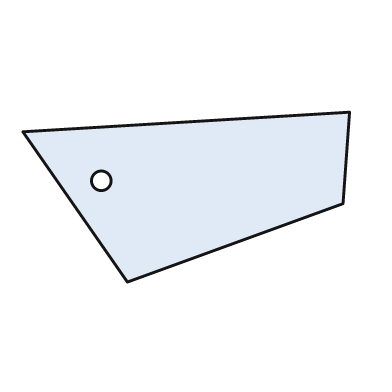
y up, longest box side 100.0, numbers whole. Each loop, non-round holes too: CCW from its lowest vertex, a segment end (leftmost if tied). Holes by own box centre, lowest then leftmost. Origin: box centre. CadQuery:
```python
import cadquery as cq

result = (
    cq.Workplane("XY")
    .moveTo(-18.0, -26.0)
    .lineTo(48.0, -2.0)
    .lineTo(50.0, 26.0)
    .lineTo(-50.0, 20.0)
    .close()
    .moveTo(-26.0, 5.0)
    .circle(3.0)
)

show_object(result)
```